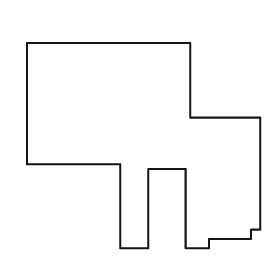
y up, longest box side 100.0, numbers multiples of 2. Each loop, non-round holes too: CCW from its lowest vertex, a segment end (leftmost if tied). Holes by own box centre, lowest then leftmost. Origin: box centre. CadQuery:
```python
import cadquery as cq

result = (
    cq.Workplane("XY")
    .moveTo(-10.0, -44.0)
    .lineTo(2.0, -44.0)
    .lineTo(2.0, -10.0)
    .lineTo(18.0, -10.0)
    .lineTo(18.0, -44.0)
    .lineTo(28.0, -44.0)
    .lineTo(28.0, -40.0)
    .lineTo(46.0, -40.0)
    .lineTo(46.0, -36.0)
    .lineTo(50.0, -36.0)
    .lineTo(50.0, 12.0)
    .lineTo(20.0, 12.0)
    .lineTo(20.0, 44.0)
    .lineTo(-50.0, 44.0)
    .lineTo(-50.0, -8.0)
    .lineTo(-10.0, -8.0)
    .close()
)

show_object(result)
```